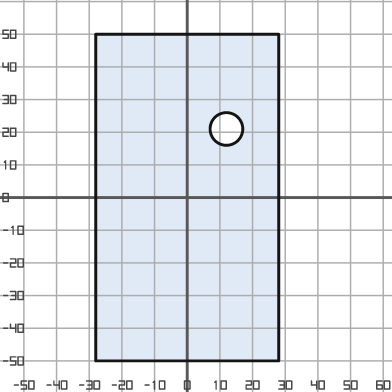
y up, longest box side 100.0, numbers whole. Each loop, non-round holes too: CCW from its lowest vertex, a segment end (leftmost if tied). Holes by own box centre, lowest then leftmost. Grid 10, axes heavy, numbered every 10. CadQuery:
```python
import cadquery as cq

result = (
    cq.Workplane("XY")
    .moveTo(-28.0, -50.0)
    .lineTo(28.0, -50.0)
    .lineTo(28.0, 50.0)
    .lineTo(-28.0, 50.0)
    .close()
    .moveTo(12.0, 21.0)
    .circle(5.0)
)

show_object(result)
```